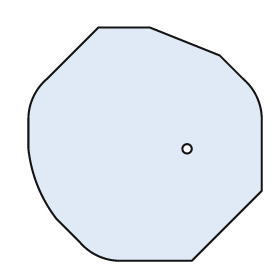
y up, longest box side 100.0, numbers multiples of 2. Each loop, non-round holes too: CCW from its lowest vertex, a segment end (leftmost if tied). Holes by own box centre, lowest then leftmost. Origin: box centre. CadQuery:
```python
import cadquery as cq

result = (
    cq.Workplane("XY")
    .moveTo(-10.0, -50.0)
    .lineTo(20.0, -50.0)
    .lineTo(50.0, -20.0)
    .lineTo(50.0, 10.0)
    .threePointArc((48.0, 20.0), (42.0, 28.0))
    .lineTo(32.0, 38.0)
    .lineTo(2.0, 50.0)
    .lineTo(-20.0, 50.0)
    .lineTo(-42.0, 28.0)
    .threePointArc((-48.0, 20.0), (-50.0, 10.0))
    .lineTo(-50.0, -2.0)
    .threePointArc((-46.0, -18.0), (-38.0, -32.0))
    .lineTo(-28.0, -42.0)
    .threePointArc((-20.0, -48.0), (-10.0, -50.0))
    .close()
    .moveTo(18.0, -2.0)
    .circle(2.0)
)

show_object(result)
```